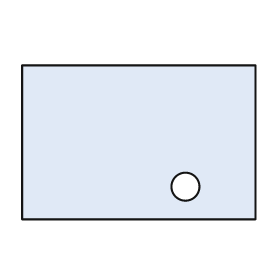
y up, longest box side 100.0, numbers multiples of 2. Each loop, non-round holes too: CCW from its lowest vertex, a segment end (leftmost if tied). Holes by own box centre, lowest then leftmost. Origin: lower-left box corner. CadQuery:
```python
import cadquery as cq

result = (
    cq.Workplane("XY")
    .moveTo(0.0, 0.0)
    .lineTo(100.0, 0.0)
    .lineTo(100.0, 66.0)
    .lineTo(0.0, 66.0)
    .close()
    .moveTo(70.0, 14.0)
    .circle(6.0)
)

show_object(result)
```